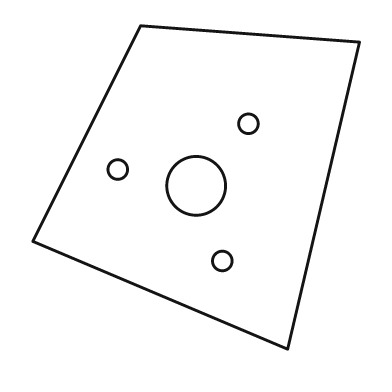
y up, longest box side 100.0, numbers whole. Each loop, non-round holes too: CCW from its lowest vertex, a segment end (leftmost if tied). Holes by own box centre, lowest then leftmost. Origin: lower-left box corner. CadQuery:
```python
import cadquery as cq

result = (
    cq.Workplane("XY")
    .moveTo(78.0, 0.0)
    .lineTo(100.0, 94.0)
    .lineTo(33.0, 99.0)
    .lineTo(0.0, 33.0)
    .close()
    .moveTo(58.0, 27.0)
    .circle(3.0)
    .moveTo(50.0, 50.0)
    .circle(9.0)
    .moveTo(26.0, 55.0)
    .circle(3.0)
    .moveTo(66.0, 69.0)
    .circle(3.0)
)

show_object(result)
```